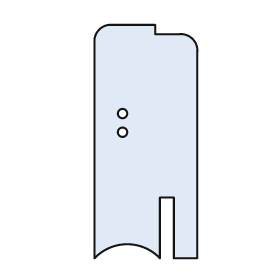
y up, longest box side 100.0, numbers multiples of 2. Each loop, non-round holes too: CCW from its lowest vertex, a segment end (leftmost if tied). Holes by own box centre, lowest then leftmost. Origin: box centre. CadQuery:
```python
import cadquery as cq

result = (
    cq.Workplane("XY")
    .moveTo(-22.0, -50.0)
    .threePointArc((-8.0, -44.0), (6.0, -50.0))
    .lineTo(6.0, -24.0)
    .lineTo(12.0, -24.0)
    .lineTo(12.0, -50.0)
    .lineTo(22.0, -50.0)
    .lineTo(22.0, 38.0)
    .threePointArc((20.0, 44.0), (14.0, 46.0))
    .lineTo(4.0, 46.0)
    .lineTo(4.0, 50.0)
    .lineTo(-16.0, 50.0)
    .threePointArc((-20.0, 48.0), (-22.0, 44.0))
    .close()
    .moveTo(-10.0, 4.0)
    .circle(2.0)
    .moveTo(-10.0, 12.0)
    .circle(2.0)
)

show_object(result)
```